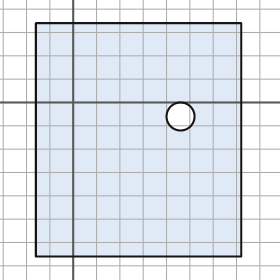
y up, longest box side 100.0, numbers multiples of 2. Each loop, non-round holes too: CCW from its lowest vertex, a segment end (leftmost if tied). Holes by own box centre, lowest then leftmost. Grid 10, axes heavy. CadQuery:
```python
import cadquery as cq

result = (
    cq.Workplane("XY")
    .moveTo(-16.0, -66.0)
    .lineTo(72.0, -66.0)
    .lineTo(72.0, 34.0)
    .lineTo(-16.0, 34.0)
    .close()
    .moveTo(46.0, -6.0)
    .circle(6.0)
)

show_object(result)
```